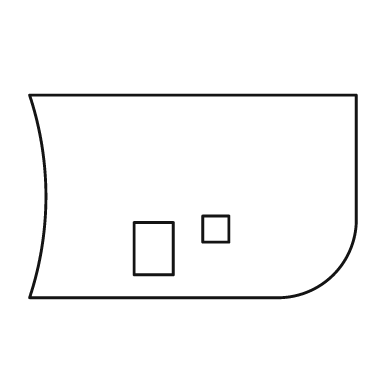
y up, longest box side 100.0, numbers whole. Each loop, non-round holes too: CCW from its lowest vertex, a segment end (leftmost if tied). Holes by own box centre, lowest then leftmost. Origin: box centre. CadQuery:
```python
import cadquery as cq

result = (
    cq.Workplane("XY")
    .moveTo(-50.0, -31.0)
    .lineTo(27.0, -31.0)
    .threePointArc((43.0, -24.0), (50.0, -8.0))
    .lineTo(50.0, 31.0)
    .lineTo(-50.0, 31.0)
    .threePointArc((-45.0, 0.0), (-50.0, -31.0))
    .close()
    .moveTo(-18.0, -24.0)
    .lineTo(-6.0, -24.0)
    .lineTo(-6.0, -8.0)
    .lineTo(-18.0, -8.0)
    .close()
    .moveTo(3.0, -14.0)
    .lineTo(11.0, -14.0)
    .lineTo(11.0, -6.0)
    .lineTo(3.0, -6.0)
    .close()
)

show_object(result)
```